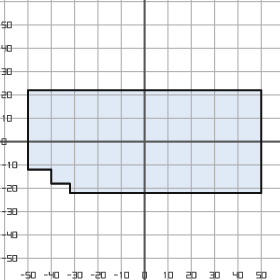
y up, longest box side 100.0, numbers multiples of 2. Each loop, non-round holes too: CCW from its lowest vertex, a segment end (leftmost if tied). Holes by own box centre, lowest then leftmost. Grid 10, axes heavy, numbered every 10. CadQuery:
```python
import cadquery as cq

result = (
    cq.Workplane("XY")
    .moveTo(-32.0, -22.0)
    .lineTo(50.0, -22.0)
    .lineTo(50.0, 22.0)
    .lineTo(-50.0, 22.0)
    .lineTo(-50.0, -12.0)
    .lineTo(-40.0, -12.0)
    .lineTo(-40.0, -18.0)
    .lineTo(-32.0, -18.0)
    .close()
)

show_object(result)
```